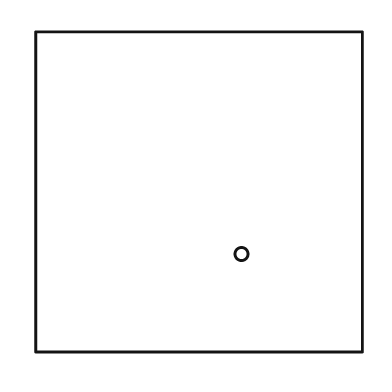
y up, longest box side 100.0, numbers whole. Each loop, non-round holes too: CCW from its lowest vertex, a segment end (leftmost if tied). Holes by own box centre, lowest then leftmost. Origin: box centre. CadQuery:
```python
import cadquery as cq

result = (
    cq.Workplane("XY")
    .moveTo(-50.0, -49.0)
    .lineTo(50.0, -49.0)
    .lineTo(50.0, 49.0)
    .lineTo(-50.0, 49.0)
    .close()
    .moveTo(13.0, -19.0)
    .circle(2.0)
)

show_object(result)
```